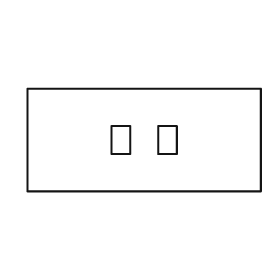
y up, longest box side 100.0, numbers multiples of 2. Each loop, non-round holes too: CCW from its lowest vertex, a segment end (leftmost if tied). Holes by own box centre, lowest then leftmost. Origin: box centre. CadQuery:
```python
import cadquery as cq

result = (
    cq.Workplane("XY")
    .moveTo(-50.0, -22.0)
    .lineTo(50.0, -22.0)
    .lineTo(50.0, 22.0)
    .lineTo(-50.0, 22.0)
    .close()
    .moveTo(-14.0, -6.0)
    .lineTo(-6.0, -6.0)
    .lineTo(-6.0, 6.0)
    .lineTo(-14.0, 6.0)
    .close()
    .moveTo(6.0, -6.0)
    .lineTo(14.0, -6.0)
    .lineTo(14.0, 6.0)
    .lineTo(6.0, 6.0)
    .close()
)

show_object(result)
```